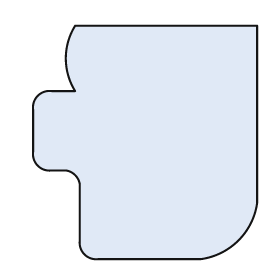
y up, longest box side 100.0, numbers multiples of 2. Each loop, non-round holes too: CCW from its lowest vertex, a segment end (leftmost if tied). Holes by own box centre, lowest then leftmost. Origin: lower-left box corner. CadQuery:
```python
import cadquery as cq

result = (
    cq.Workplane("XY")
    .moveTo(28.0, 0.0)
    .lineTo(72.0, 0.0)
    .threePointArc((88.0, 8.0), (96.0, 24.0))
    .lineTo(96.0, 100.0)
    .lineTo(18.0, 100.0)
    .threePointArc((14.0, 86.0), (18.0, 72.0))
    .lineTo(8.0, 72.0)
    .threePointArc((2.0, 70.0), (0.0, 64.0))
    .lineTo(0.0, 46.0)
    .threePointArc((2.0, 40.0), (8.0, 38.0))
    .lineTo(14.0, 38.0)
    .threePointArc((18.0, 36.0), (20.0, 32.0))
    .lineTo(20.0, 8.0)
    .threePointArc((22.0, 2.0), (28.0, 0.0))
    .close()
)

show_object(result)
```